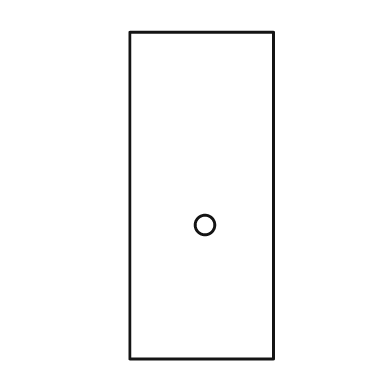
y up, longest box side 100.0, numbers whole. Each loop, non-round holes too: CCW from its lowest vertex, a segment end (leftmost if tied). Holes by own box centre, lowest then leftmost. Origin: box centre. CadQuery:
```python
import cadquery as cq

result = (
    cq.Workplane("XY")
    .moveTo(-22.0, -50.0)
    .lineTo(22.0, -50.0)
    .lineTo(22.0, 50.0)
    .lineTo(-22.0, 50.0)
    .close()
    .moveTo(1.0, -9.0)
    .circle(3.0)
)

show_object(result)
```